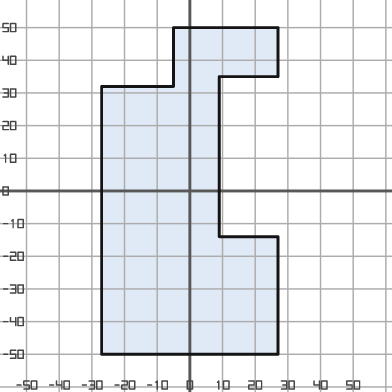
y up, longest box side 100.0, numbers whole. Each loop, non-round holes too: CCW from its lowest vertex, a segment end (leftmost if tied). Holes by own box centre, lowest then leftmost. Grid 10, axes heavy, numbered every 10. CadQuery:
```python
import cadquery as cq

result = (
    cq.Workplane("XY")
    .moveTo(-27.0, -50.0)
    .lineTo(27.0, -50.0)
    .lineTo(27.0, -14.0)
    .lineTo(9.0, -14.0)
    .lineTo(9.0, 35.0)
    .lineTo(27.0, 35.0)
    .lineTo(27.0, 50.0)
    .lineTo(-5.0, 50.0)
    .lineTo(-5.0, 32.0)
    .lineTo(-27.0, 32.0)
    .close()
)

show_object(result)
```